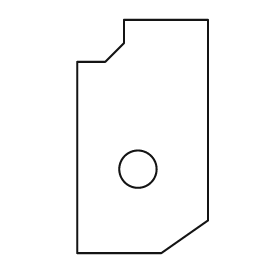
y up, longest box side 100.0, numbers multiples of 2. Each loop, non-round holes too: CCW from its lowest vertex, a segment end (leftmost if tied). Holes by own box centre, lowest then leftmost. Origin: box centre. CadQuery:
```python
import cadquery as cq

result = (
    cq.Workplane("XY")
    .moveTo(-28.0, -50.0)
    .lineTo(8.0, -50.0)
    .lineTo(28.0, -36.0)
    .lineTo(28.0, 50.0)
    .lineTo(-8.0, 50.0)
    .lineTo(-8.0, 40.0)
    .lineTo(-16.0, 32.0)
    .lineTo(-28.0, 32.0)
    .close()
    .moveTo(-2.0, -14.0)
    .circle(8.0)
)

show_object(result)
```